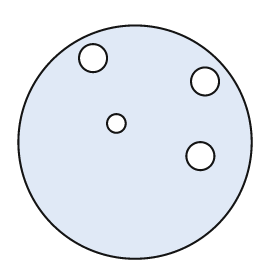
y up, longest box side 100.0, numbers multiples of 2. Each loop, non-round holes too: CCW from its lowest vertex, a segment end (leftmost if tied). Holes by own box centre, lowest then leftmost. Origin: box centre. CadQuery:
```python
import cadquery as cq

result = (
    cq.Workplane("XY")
    .moveTo(0.0, 0.0)
    .circle(50.0)
    .moveTo(28.0, -6.0)
    .circle(6.0)
    .moveTo(-8.0, 8.0)
    .circle(4.0)
    .moveTo(30.0, 26.0)
    .circle(6.0)
    .moveTo(-18.0, 36.0)
    .circle(6.0)
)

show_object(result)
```